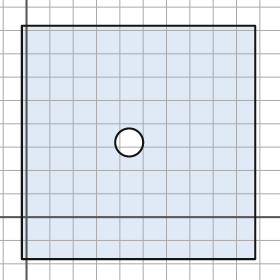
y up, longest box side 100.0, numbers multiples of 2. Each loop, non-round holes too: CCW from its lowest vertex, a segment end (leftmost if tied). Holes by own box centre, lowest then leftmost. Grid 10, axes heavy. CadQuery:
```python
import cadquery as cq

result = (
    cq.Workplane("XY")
    .moveTo(-2.0, -18.0)
    .lineTo(98.0, -18.0)
    .lineTo(98.0, 82.0)
    .lineTo(-2.0, 82.0)
    .close()
    .moveTo(44.0, 32.0)
    .circle(6.0)
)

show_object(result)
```